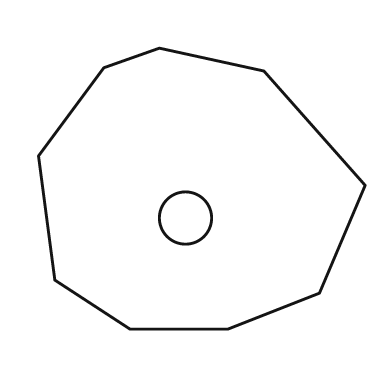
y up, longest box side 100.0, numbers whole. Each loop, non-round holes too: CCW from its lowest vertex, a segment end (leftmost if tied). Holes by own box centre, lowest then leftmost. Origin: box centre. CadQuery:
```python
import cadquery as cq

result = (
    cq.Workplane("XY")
    .moveTo(-22.0, -43.0)
    .lineTo(8.0, -43.0)
    .lineTo(36.0, -32.0)
    .lineTo(50.0, 1.0)
    .lineTo(19.0, 36.0)
    .lineTo(-13.0, 43.0)
    .lineTo(-30.0, 37.0)
    .lineTo(-50.0, 10.0)
    .lineTo(-45.0, -28.0)
    .close()
    .moveTo(-5.0, -9.0)
    .circle(8.0)
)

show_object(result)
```